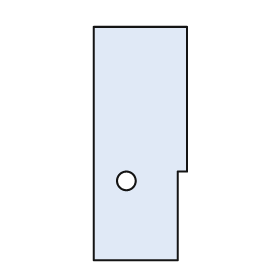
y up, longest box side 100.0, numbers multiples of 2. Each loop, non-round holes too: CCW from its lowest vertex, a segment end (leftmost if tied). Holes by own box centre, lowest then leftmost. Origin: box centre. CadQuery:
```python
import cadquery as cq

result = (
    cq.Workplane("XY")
    .moveTo(-20.0, -50.0)
    .lineTo(16.0, -50.0)
    .lineTo(16.0, -12.0)
    .lineTo(20.0, -12.0)
    .lineTo(20.0, 50.0)
    .lineTo(-20.0, 50.0)
    .close()
    .moveTo(-6.0, -16.0)
    .circle(4.0)
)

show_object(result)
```